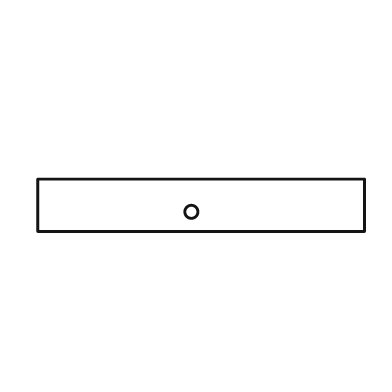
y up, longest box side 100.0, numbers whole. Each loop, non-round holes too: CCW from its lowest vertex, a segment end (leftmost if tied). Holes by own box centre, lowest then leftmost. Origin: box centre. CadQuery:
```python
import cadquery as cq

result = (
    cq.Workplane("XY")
    .moveTo(-50.0, -8.0)
    .lineTo(50.0, -8.0)
    .lineTo(50.0, 8.0)
    .lineTo(-50.0, 8.0)
    .close()
    .moveTo(-3.0, -2.0)
    .circle(2.0)
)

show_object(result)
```